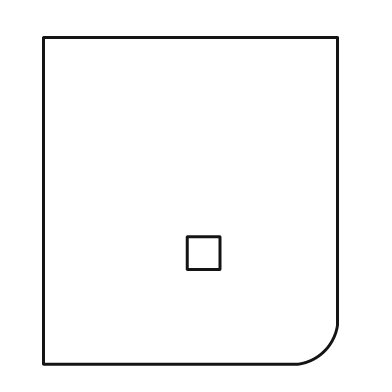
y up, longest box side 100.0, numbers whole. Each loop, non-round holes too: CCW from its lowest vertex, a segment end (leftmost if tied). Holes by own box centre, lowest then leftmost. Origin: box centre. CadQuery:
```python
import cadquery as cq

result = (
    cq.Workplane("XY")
    .moveTo(-45.0, -50.0)
    .lineTo(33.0, -50.0)
    .threePointArc((41.0, -46.0), (45.0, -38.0))
    .lineTo(45.0, 50.0)
    .lineTo(-45.0, 50.0)
    .close()
    .moveTo(-1.0, -21.0)
    .lineTo(9.0, -21.0)
    .lineTo(9.0, -11.0)
    .lineTo(-1.0, -11.0)
    .close()
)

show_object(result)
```